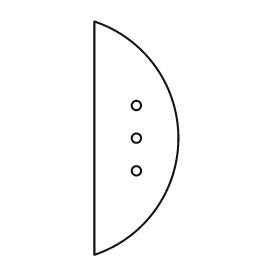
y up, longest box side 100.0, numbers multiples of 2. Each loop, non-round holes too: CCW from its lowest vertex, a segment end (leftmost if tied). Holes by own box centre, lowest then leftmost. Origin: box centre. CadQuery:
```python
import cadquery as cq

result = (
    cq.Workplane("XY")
    .moveTo(-18.0, -50.0)
    .threePointArc((18.0, 0.0), (-18.0, 50.0))
    .close()
    .moveTo(0.0, -14.0)
    .circle(2.0)
    .moveTo(0.0, 0.0)
    .circle(2.0)
    .moveTo(0.0, 14.0)
    .circle(2.0)
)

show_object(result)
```